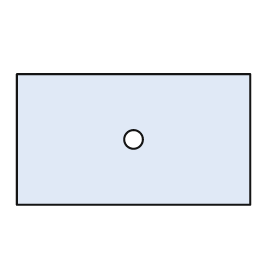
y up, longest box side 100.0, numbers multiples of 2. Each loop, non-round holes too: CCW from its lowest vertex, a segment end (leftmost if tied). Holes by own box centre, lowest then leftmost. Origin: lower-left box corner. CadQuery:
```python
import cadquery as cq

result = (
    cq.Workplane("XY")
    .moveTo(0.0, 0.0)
    .lineTo(100.0, 0.0)
    .lineTo(100.0, 56.0)
    .lineTo(0.0, 56.0)
    .close()
    .moveTo(50.0, 28.0)
    .circle(4.0)
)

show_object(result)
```